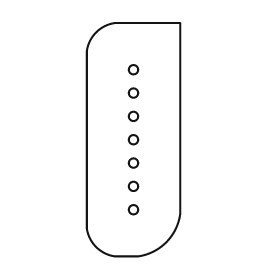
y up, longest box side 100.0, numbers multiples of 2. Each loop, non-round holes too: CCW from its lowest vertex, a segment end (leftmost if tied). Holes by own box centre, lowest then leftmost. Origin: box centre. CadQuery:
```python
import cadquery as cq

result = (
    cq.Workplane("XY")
    .moveTo(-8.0, -50.0)
    .lineTo(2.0, -50.0)
    .threePointArc((14.0, -44.0), (20.0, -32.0))
    .lineTo(20.0, 50.0)
    .lineTo(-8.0, 50.0)
    .threePointArc((-16.0, 46.0), (-20.0, 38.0))
    .lineTo(-20.0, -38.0)
    .threePointArc((-16.0, -46.0), (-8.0, -50.0))
    .close()
    .moveTo(0.0, -30.0)
    .circle(2.0)
    .moveTo(0.0, -20.0)
    .circle(2.0)
    .moveTo(0.0, -10.0)
    .circle(2.0)
    .moveTo(0.0, 0.0)
    .circle(2.0)
    .moveTo(0.0, 10.0)
    .circle(2.0)
    .moveTo(0.0, 20.0)
    .circle(2.0)
    .moveTo(0.0, 30.0)
    .circle(2.0)
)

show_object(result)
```